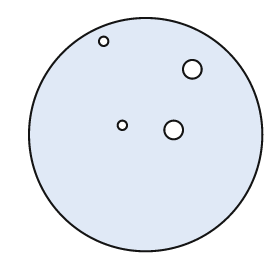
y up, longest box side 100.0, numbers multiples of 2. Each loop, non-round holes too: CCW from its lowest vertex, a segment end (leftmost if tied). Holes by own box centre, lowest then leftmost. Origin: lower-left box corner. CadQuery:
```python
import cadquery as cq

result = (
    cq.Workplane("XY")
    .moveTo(50.0, 50.0)
    .circle(50.0)
    .moveTo(62.0, 52.0)
    .circle(4.0)
    .moveTo(40.0, 54.0)
    .circle(2.0)
    .moveTo(70.0, 78.0)
    .circle(4.0)
    .moveTo(32.0, 90.0)
    .circle(2.0)
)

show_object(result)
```